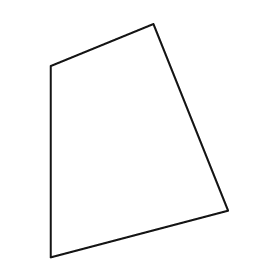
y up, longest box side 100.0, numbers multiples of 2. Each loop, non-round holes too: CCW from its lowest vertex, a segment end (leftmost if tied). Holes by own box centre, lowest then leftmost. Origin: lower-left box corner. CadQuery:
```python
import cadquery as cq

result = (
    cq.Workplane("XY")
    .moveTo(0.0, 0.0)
    .lineTo(76.0, 20.0)
    .lineTo(44.0, 100.0)
    .lineTo(0.0, 82.0)
    .close()
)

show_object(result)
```